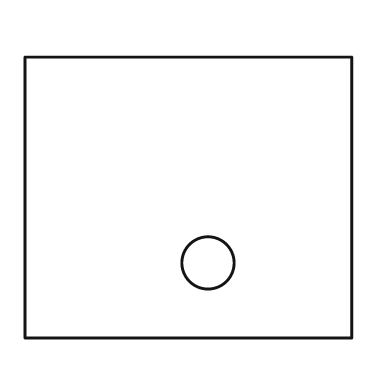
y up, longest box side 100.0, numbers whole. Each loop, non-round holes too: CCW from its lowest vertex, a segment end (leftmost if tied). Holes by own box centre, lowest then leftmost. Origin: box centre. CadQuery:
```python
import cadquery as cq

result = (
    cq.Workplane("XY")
    .moveTo(-50.0, -43.0)
    .lineTo(50.0, -43.0)
    .lineTo(50.0, 43.0)
    .lineTo(-50.0, 43.0)
    .close()
    .moveTo(6.0, -20.0)
    .circle(8.0)
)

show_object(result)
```